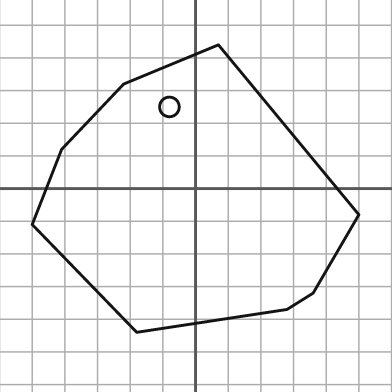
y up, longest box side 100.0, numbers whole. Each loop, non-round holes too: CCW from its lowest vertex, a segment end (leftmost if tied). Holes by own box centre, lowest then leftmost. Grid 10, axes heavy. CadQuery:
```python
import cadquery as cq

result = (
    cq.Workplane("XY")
    .moveTo(-18.0, -44.0)
    .lineTo(28.0, -37.0)
    .lineTo(36.0, -32.0)
    .lineTo(50.0, -8.0)
    .lineTo(7.0, 44.0)
    .lineTo(-22.0, 32.0)
    .lineTo(-41.0, 12.0)
    .lineTo(-50.0, -11.0)
    .close()
    .moveTo(-8.0, 25.0)
    .circle(3.0)
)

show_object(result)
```